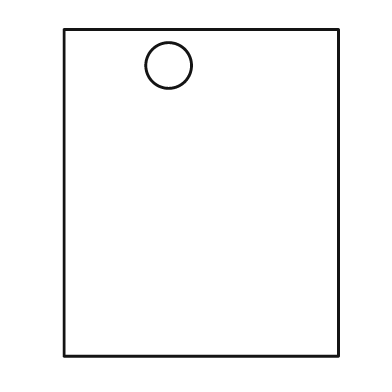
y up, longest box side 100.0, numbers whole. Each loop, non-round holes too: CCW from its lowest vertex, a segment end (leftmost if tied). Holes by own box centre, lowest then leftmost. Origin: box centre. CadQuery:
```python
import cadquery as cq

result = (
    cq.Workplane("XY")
    .moveTo(-42.0, -50.0)
    .lineTo(42.0, -50.0)
    .lineTo(42.0, 50.0)
    .lineTo(-42.0, 50.0)
    .close()
    .moveTo(-10.0, 39.0)
    .circle(7.0)
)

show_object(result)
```